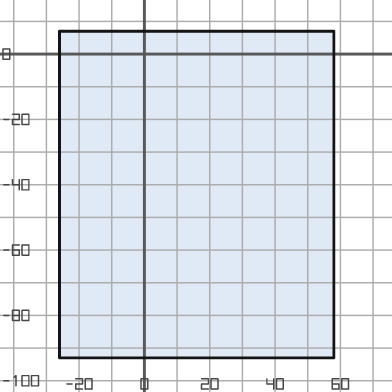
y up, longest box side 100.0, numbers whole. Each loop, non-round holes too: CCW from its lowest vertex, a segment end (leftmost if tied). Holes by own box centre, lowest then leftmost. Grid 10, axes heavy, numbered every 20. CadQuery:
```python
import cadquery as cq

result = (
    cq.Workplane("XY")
    .moveTo(-26.0, -93.0)
    .lineTo(58.0, -93.0)
    .lineTo(58.0, 7.0)
    .lineTo(-26.0, 7.0)
    .close()
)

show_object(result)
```